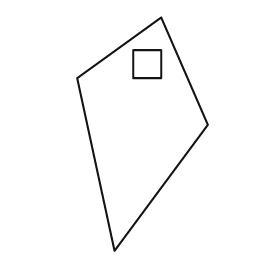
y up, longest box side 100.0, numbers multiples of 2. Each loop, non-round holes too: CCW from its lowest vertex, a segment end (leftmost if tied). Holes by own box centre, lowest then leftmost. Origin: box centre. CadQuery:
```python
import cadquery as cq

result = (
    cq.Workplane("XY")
    .moveTo(-12.0, -50.0)
    .lineTo(28.0, 4.0)
    .lineTo(8.0, 50.0)
    .lineTo(-28.0, 24.0)
    .close()
    .moveTo(-4.0, 24.0)
    .lineTo(8.0, 24.0)
    .lineTo(8.0, 36.0)
    .lineTo(-4.0, 36.0)
    .close()
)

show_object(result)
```